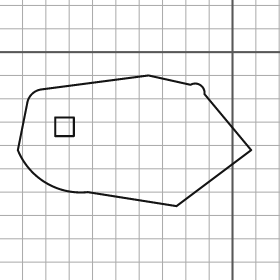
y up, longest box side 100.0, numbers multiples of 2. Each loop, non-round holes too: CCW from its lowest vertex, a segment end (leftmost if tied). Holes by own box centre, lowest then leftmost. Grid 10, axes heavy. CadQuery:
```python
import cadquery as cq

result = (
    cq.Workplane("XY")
    .moveTo(-24.0, -66.0)
    .lineTo(8.0, -42.0)
    .lineTo(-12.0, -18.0)
    .threePointArc((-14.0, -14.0), (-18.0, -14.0))
    .lineTo(-36.0, -10.0)
    .lineTo(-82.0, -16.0)
    .threePointArc((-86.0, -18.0), (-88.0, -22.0))
    .lineTo(-92.0, -42.0)
    .threePointArc((-80.0, -56.0), (-62.0, -60.0))
    .close()
    .moveTo(-76.0, -36.0)
    .lineTo(-68.0, -36.0)
    .lineTo(-68.0, -28.0)
    .lineTo(-76.0, -28.0)
    .close()
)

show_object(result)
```